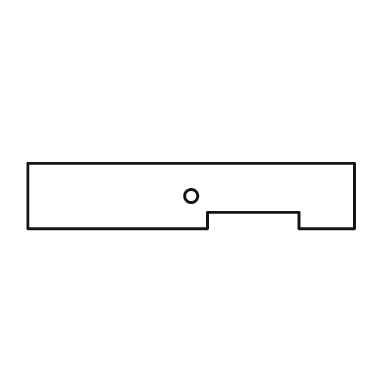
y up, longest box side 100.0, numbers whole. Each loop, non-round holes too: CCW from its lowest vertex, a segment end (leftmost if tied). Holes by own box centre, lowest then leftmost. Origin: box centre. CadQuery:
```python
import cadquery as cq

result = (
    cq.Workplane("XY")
    .moveTo(-50.0, -10.0)
    .lineTo(5.0, -10.0)
    .lineTo(5.0, -5.0)
    .lineTo(33.0, -5.0)
    .lineTo(33.0, -10.0)
    .lineTo(50.0, -10.0)
    .lineTo(50.0, 10.0)
    .lineTo(-50.0, 10.0)
    .close()
    .moveTo(0.0, 0.0)
    .circle(2.0)
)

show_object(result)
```